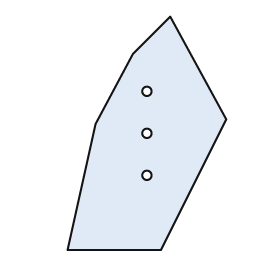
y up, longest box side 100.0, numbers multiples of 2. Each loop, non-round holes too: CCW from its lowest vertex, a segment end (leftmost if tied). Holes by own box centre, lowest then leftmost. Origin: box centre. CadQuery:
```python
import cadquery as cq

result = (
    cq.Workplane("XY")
    .moveTo(-34.0, -50.0)
    .lineTo(6.0, -50.0)
    .lineTo(34.0, 6.0)
    .lineTo(10.0, 50.0)
    .lineTo(-6.0, 34.0)
    .lineTo(-22.0, 4.0)
    .close()
    .moveTo(0.0, -18.0)
    .circle(2.0)
    .moveTo(0.0, 0.0)
    .circle(2.0)
    .moveTo(0.0, 18.0)
    .circle(2.0)
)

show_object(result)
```